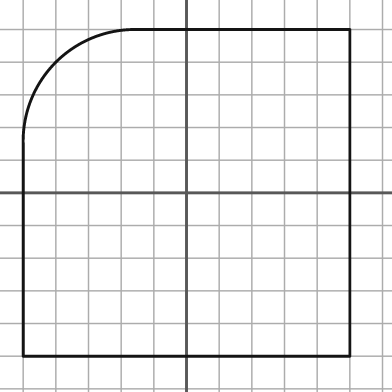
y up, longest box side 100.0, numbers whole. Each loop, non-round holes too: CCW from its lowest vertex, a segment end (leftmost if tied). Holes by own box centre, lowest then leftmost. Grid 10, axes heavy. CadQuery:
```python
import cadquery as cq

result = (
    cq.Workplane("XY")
    .moveTo(-50.0, -50.0)
    .lineTo(50.0, -50.0)
    .lineTo(50.0, 50.0)
    .lineTo(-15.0, 50.0)
    .threePointArc((-40.0, 40.0), (-50.0, 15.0))
    .close()
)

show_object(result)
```